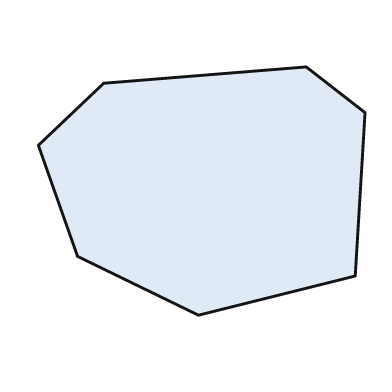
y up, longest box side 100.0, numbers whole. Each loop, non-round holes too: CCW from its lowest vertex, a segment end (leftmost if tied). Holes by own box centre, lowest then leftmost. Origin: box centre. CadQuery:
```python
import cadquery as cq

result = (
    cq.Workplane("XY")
    .moveTo(-1.0, -38.0)
    .lineTo(47.0, -26.0)
    .lineTo(50.0, 24.0)
    .lineTo(32.0, 38.0)
    .lineTo(-30.0, 33.0)
    .lineTo(-50.0, 14.0)
    .lineTo(-38.0, -20.0)
    .close()
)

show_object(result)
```